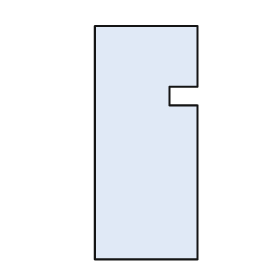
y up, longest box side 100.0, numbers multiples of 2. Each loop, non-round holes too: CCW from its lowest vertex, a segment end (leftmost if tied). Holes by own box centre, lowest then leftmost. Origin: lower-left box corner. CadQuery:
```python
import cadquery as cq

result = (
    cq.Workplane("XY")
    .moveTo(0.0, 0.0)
    .lineTo(44.0, 0.0)
    .lineTo(44.0, 66.0)
    .lineTo(32.0, 66.0)
    .lineTo(32.0, 74.0)
    .lineTo(44.0, 74.0)
    .lineTo(44.0, 100.0)
    .lineTo(0.0, 100.0)
    .close()
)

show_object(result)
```